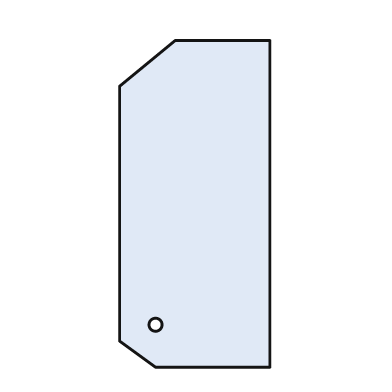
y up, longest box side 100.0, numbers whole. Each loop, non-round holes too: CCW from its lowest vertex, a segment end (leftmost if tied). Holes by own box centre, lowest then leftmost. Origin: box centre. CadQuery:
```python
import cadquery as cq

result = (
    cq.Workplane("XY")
    .moveTo(-12.0, -50.0)
    .lineTo(23.0, -50.0)
    .lineTo(23.0, 50.0)
    .lineTo(-6.0, 50.0)
    .lineTo(-23.0, 36.0)
    .lineTo(-23.0, -42.0)
    .close()
    .moveTo(-12.0, -37.0)
    .circle(2.0)
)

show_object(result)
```